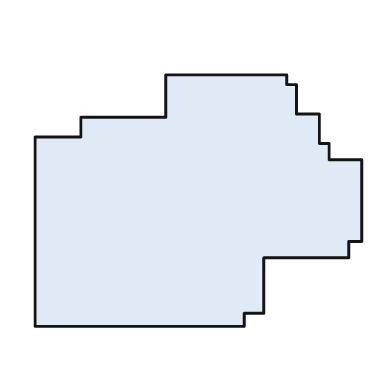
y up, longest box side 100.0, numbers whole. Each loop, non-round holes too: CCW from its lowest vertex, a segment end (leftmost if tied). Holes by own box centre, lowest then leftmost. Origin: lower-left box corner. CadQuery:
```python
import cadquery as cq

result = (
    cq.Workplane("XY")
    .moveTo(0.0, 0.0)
    .lineTo(64.0, 0.0)
    .lineTo(64.0, 4.0)
    .lineTo(70.0, 4.0)
    .lineTo(70.0, 21.0)
    .lineTo(96.0, 21.0)
    .lineTo(96.0, 26.0)
    .lineTo(100.0, 26.0)
    .lineTo(100.0, 51.0)
    .lineTo(90.0, 51.0)
    .lineTo(90.0, 56.0)
    .lineTo(87.0, 56.0)
    .lineTo(87.0, 65.0)
    .lineTo(80.0, 65.0)
    .lineTo(80.0, 74.0)
    .lineTo(77.0, 74.0)
    .lineTo(77.0, 77.0)
    .lineTo(40.0, 77.0)
    .lineTo(40.0, 64.0)
    .lineTo(14.0, 64.0)
    .lineTo(14.0, 58.0)
    .lineTo(0.0, 58.0)
    .close()
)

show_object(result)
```